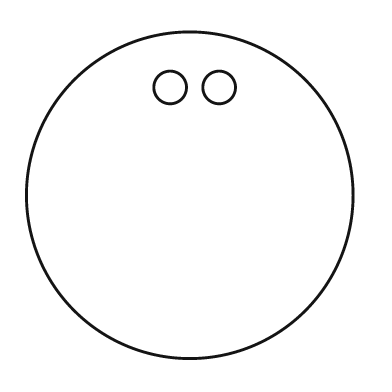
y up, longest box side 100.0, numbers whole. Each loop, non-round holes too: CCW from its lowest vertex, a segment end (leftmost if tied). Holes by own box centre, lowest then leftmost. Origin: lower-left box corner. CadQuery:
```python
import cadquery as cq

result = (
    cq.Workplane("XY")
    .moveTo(50.0, 50.0)
    .circle(50.0)
    .moveTo(44.0, 83.0)
    .circle(5.0)
    .moveTo(59.0, 83.0)
    .circle(5.0)
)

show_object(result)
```